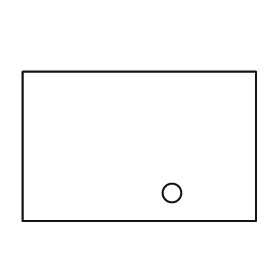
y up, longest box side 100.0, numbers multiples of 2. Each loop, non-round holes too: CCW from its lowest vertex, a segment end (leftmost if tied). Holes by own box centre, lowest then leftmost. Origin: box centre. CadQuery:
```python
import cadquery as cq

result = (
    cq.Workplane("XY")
    .moveTo(-50.0, -32.0)
    .lineTo(50.0, -32.0)
    .lineTo(50.0, 32.0)
    .lineTo(-50.0, 32.0)
    .close()
    .moveTo(14.0, -20.0)
    .circle(4.0)
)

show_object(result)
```